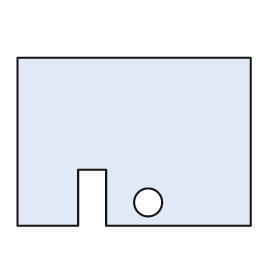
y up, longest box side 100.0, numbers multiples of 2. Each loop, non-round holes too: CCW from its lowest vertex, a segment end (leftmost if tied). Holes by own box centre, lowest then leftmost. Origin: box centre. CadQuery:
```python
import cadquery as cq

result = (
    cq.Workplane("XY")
    .moveTo(-50.0, -36.0)
    .lineTo(-24.0, -36.0)
    .lineTo(-24.0, -12.0)
    .lineTo(-12.0, -12.0)
    .lineTo(-12.0, -36.0)
    .lineTo(50.0, -36.0)
    .lineTo(50.0, 36.0)
    .lineTo(-50.0, 36.0)
    .close()
    .moveTo(6.0, -26.0)
    .circle(6.0)
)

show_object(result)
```